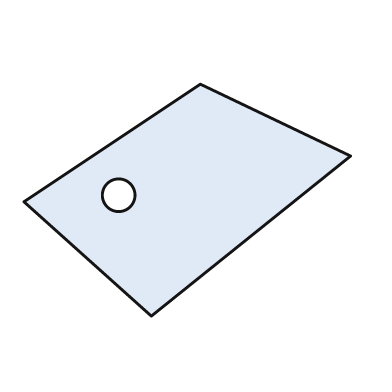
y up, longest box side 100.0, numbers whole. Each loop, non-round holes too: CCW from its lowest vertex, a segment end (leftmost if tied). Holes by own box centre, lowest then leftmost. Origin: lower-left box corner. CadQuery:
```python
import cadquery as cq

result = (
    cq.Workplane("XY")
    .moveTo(39.0, 0.0)
    .lineTo(100.0, 49.0)
    .lineTo(54.0, 71.0)
    .lineTo(0.0, 35.0)
    .close()
    .moveTo(29.0, 37.0)
    .circle(5.0)
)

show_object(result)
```